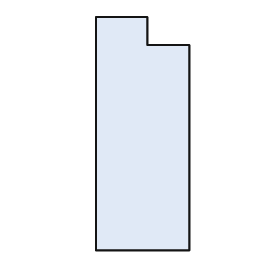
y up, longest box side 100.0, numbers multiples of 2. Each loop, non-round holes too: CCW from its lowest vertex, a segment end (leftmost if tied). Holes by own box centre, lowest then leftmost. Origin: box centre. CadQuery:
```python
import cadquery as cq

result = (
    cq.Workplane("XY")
    .moveTo(-20.0, -50.0)
    .lineTo(20.0, -50.0)
    .lineTo(20.0, 38.0)
    .lineTo(2.0, 38.0)
    .lineTo(2.0, 50.0)
    .lineTo(-20.0, 50.0)
    .close()
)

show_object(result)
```